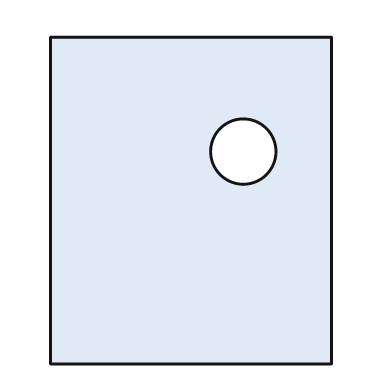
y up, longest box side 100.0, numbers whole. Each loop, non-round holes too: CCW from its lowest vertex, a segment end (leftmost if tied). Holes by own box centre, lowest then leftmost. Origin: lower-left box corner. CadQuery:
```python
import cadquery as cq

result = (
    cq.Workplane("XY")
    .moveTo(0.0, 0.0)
    .lineTo(86.0, 0.0)
    .lineTo(86.0, 100.0)
    .lineTo(0.0, 100.0)
    .close()
    .moveTo(59.0, 65.0)
    .circle(10.0)
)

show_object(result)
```